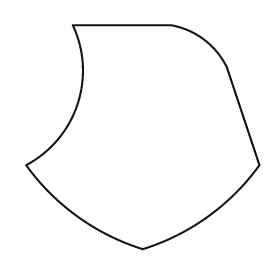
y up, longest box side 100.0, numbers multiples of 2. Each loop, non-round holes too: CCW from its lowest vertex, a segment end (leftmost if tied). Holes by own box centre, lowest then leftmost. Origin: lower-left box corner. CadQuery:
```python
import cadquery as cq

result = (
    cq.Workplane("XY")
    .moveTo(50.0, 0.0)
    .threePointArc((78.0, 14.0), (100.0, 36.0))
    .lineTo(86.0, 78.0)
    .threePointArc((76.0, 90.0), (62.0, 96.0))
    .lineTo(20.0, 96.0)
    .threePointArc((22.0, 62.0), (0.0, 36.0))
    .threePointArc((22.0, 14.0), (50.0, 0.0))
    .close()
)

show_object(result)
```